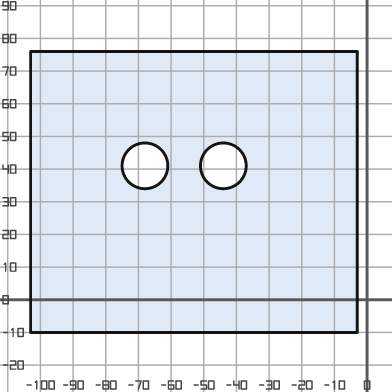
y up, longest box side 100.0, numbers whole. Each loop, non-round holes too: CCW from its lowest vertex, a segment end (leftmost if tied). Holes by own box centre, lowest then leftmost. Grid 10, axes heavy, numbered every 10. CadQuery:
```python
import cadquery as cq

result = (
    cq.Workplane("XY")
    .moveTo(-103.0, -10.0)
    .lineTo(-3.0, -10.0)
    .lineTo(-3.0, 76.0)
    .lineTo(-103.0, 76.0)
    .close()
    .moveTo(-68.0, 41.0)
    .circle(7.0)
    .moveTo(-44.0, 41.0)
    .circle(7.0)
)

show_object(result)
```